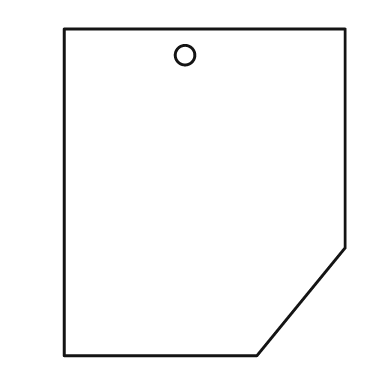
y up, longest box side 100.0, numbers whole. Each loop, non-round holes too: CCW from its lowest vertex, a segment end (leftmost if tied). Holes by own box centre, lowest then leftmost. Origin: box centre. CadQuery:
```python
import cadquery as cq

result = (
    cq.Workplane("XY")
    .moveTo(-43.0, -50.0)
    .lineTo(16.0, -50.0)
    .lineTo(43.0, -17.0)
    .lineTo(43.0, 50.0)
    .lineTo(-43.0, 50.0)
    .close()
    .moveTo(-6.0, 42.0)
    .circle(3.0)
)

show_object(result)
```